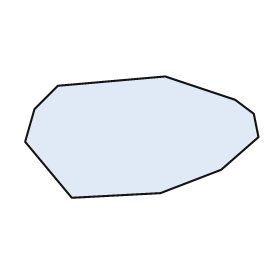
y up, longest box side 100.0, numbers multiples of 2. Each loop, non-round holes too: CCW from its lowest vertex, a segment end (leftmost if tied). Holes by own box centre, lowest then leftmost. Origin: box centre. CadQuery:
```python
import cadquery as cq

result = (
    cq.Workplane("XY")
    .moveTo(-30.0, -26.0)
    .lineTo(8.0, -24.0)
    .lineTo(34.0, -14.0)
    .lineTo(50.0, 0.0)
    .lineTo(48.0, 10.0)
    .lineTo(40.0, 16.0)
    .lineTo(10.0, 26.0)
    .lineTo(-36.0, 22.0)
    .lineTo(-46.0, 12.0)
    .lineTo(-50.0, -2.0)
    .close()
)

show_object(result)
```